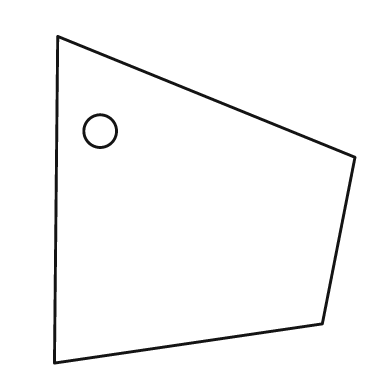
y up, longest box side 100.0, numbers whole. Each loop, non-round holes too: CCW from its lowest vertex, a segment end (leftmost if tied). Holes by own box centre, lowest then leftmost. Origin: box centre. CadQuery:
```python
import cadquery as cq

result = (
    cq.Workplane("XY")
    .moveTo(-46.0, -50.0)
    .lineTo(36.0, -38.0)
    .lineTo(46.0, 13.0)
    .lineTo(-45.0, 50.0)
    .close()
    .moveTo(-32.0, 21.0)
    .circle(5.0)
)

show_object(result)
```